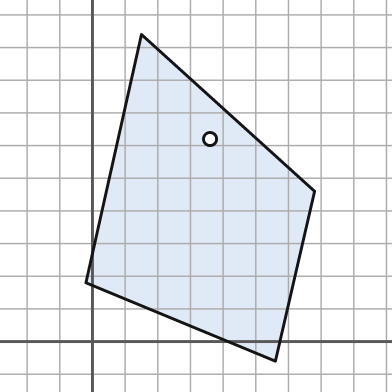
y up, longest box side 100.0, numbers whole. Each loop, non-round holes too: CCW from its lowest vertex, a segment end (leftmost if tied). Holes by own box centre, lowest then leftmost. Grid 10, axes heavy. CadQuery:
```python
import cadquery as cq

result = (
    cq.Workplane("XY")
    .moveTo(56.0, -6.0)
    .lineTo(68.0, 46.0)
    .lineTo(15.0, 94.0)
    .lineTo(-2.0, 18.0)
    .close()
    .moveTo(36.0, 62.0)
    .circle(2.0)
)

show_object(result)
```